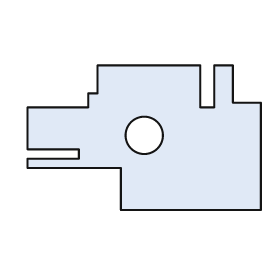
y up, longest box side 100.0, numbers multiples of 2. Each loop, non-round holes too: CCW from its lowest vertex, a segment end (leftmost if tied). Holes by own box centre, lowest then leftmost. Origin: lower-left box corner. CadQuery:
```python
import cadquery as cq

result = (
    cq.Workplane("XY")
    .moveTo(40.0, 0.0)
    .lineTo(100.0, 0.0)
    .lineTo(100.0, 46.0)
    .lineTo(88.0, 46.0)
    .lineTo(88.0, 62.0)
    .lineTo(80.0, 62.0)
    .lineTo(80.0, 44.0)
    .lineTo(74.0, 44.0)
    .lineTo(74.0, 62.0)
    .lineTo(30.0, 62.0)
    .lineTo(30.0, 50.0)
    .lineTo(26.0, 50.0)
    .lineTo(26.0, 44.0)
    .lineTo(0.0, 44.0)
    .lineTo(0.0, 26.0)
    .lineTo(22.0, 26.0)
    .lineTo(22.0, 22.0)
    .lineTo(0.0, 22.0)
    .lineTo(0.0, 18.0)
    .lineTo(40.0, 18.0)
    .close()
    .moveTo(50.0, 32.0)
    .circle(8.0)
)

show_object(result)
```